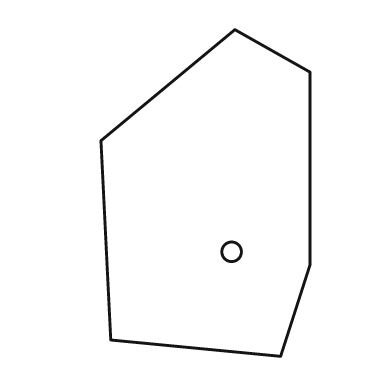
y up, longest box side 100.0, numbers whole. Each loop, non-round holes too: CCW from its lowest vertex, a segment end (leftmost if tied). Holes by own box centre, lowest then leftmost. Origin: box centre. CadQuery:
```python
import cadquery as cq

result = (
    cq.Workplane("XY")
    .moveTo(23.0, -50.0)
    .lineTo(32.0, -22.0)
    .lineTo(32.0, 37.0)
    .lineTo(9.0, 50.0)
    .lineTo(-32.0, 16.0)
    .lineTo(-29.0, -45.0)
    .close()
    .moveTo(8.0, -18.0)
    .circle(3.0)
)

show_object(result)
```